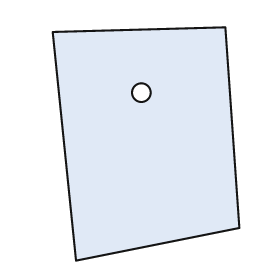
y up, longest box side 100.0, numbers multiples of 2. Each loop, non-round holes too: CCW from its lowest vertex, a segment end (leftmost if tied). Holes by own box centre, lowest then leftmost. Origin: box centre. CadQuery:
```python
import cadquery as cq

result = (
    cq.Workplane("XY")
    .moveTo(-30.0, -50.0)
    .lineTo(40.0, -36.0)
    .lineTo(34.0, 50.0)
    .lineTo(-40.0, 48.0)
    .close()
    .moveTo(-2.0, 22.0)
    .circle(4.0)
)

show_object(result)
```